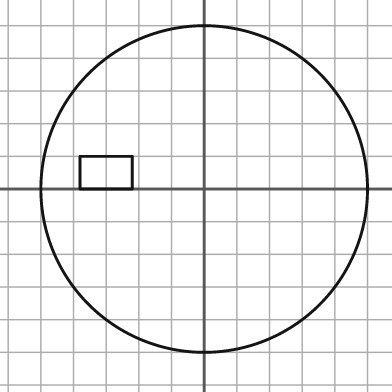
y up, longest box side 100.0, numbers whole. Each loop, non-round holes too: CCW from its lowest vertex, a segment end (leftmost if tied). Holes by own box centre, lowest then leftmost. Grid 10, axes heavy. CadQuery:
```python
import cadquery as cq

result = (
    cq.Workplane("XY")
    .moveTo(0.0, 0.0)
    .circle(50.0)
    .moveTo(-38.0, 0.0)
    .lineTo(-22.0, 0.0)
    .lineTo(-22.0, 10.0)
    .lineTo(-38.0, 10.0)
    .close()
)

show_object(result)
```